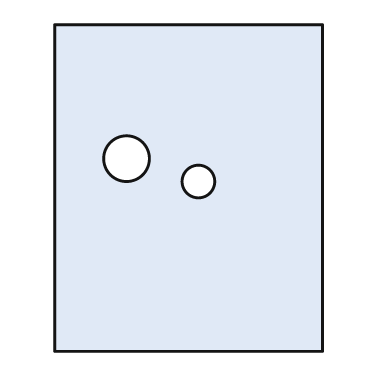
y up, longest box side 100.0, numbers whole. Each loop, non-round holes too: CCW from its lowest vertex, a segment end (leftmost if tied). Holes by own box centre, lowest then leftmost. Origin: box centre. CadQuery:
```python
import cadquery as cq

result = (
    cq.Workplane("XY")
    .moveTo(-41.0, -50.0)
    .lineTo(41.0, -50.0)
    .lineTo(41.0, 50.0)
    .lineTo(-41.0, 50.0)
    .close()
    .moveTo(3.0, 2.0)
    .circle(5.0)
    .moveTo(-19.0, 9.0)
    .circle(7.0)
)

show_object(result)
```